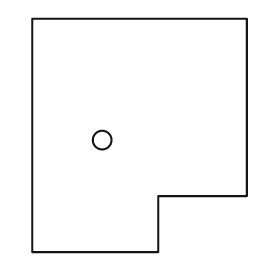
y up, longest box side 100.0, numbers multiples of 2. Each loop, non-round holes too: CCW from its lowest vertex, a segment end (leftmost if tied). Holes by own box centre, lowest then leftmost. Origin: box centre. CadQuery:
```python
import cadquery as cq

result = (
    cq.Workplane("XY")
    .moveTo(-46.0, -50.0)
    .lineTo(8.0, -50.0)
    .lineTo(8.0, -26.0)
    .lineTo(46.0, -26.0)
    .lineTo(46.0, 50.0)
    .lineTo(-46.0, 50.0)
    .close()
    .moveTo(-16.0, -2.0)
    .circle(4.0)
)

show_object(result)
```